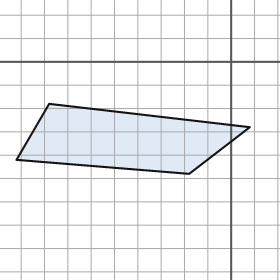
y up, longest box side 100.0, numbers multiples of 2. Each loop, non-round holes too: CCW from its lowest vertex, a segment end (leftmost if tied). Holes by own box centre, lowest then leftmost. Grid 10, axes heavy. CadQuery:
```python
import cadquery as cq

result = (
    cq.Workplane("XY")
    .moveTo(-18.0, -48.0)
    .lineTo(8.0, -28.0)
    .lineTo(-78.0, -18.0)
    .lineTo(-92.0, -42.0)
    .close()
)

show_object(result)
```